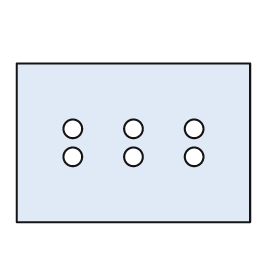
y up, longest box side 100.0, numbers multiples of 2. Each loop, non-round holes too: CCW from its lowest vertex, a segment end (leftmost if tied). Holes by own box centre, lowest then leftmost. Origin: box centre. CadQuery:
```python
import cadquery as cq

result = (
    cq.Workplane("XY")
    .moveTo(-50.0, -34.0)
    .lineTo(50.0, -34.0)
    .lineTo(50.0, 34.0)
    .lineTo(-50.0, 34.0)
    .close()
    .moveTo(-26.0, -6.0)
    .circle(4.0)
    .moveTo(0.0, -6.0)
    .circle(4.0)
    .moveTo(26.0, -6.0)
    .circle(4.0)
    .moveTo(-26.0, 6.0)
    .circle(4.0)
    .moveTo(0.0, 6.0)
    .circle(4.0)
    .moveTo(26.0, 6.0)
    .circle(4.0)
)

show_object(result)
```